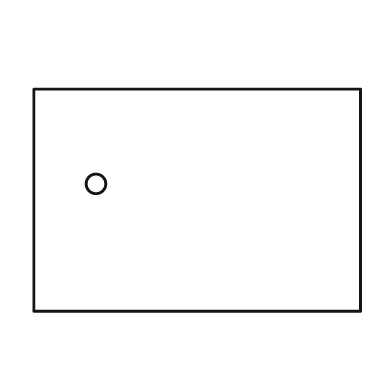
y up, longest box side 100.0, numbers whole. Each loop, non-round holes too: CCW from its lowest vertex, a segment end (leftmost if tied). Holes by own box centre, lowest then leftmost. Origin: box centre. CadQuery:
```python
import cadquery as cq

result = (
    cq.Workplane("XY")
    .moveTo(-50.0, -34.0)
    .lineTo(50.0, -34.0)
    .lineTo(50.0, 34.0)
    .lineTo(-50.0, 34.0)
    .close()
    .moveTo(-31.0, 5.0)
    .circle(3.0)
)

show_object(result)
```